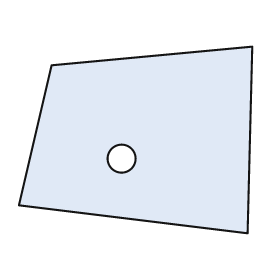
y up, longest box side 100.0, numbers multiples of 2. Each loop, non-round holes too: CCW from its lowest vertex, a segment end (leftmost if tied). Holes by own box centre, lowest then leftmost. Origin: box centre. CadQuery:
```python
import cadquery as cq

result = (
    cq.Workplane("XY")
    .moveTo(48.0, -40.0)
    .lineTo(50.0, 40.0)
    .lineTo(-36.0, 32.0)
    .lineTo(-50.0, -28.0)
    .close()
    .moveTo(-6.0, -8.0)
    .circle(6.0)
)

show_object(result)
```